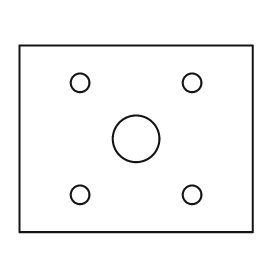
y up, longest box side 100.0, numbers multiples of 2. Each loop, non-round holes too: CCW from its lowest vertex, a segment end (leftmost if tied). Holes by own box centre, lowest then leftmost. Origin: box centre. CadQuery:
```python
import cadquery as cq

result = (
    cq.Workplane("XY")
    .moveTo(-50.0, -40.0)
    .lineTo(50.0, -40.0)
    .lineTo(50.0, 40.0)
    .lineTo(-50.0, 40.0)
    .close()
    .moveTo(-24.0, -24.0)
    .circle(4.0)
    .moveTo(24.0, -24.0)
    .circle(4.0)
    .moveTo(0.0, 0.0)
    .circle(10.0)
    .moveTo(-24.0, 24.0)
    .circle(4.0)
    .moveTo(24.0, 24.0)
    .circle(4.0)
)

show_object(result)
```